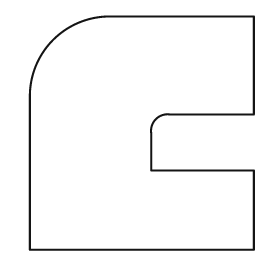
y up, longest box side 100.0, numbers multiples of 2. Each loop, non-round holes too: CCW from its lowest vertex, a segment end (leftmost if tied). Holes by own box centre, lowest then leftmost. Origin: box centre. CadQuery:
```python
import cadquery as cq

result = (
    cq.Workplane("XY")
    .moveTo(-48.0, -50.0)
    .lineTo(48.0, -50.0)
    .lineTo(48.0, -16.0)
    .lineTo(4.0, -16.0)
    .lineTo(4.0, 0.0)
    .threePointArc((6.0, 6.0), (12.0, 8.0))
    .lineTo(48.0, 8.0)
    .lineTo(48.0, 50.0)
    .lineTo(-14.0, 50.0)
    .threePointArc((-38.0, 40.0), (-48.0, 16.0))
    .close()
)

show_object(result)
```